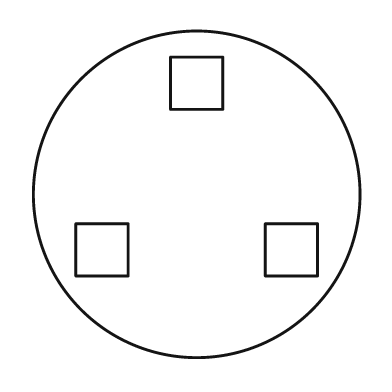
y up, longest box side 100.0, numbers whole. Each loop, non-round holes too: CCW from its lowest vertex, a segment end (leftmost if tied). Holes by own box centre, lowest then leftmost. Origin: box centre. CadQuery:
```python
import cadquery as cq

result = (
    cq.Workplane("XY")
    .moveTo(0.0, 0.0)
    .circle(50.0)
    .moveTo(-37.0, -25.0)
    .lineTo(-21.0, -25.0)
    .lineTo(-21.0, -9.0)
    .lineTo(-37.0, -9.0)
    .close()
    .moveTo(21.0, -25.0)
    .lineTo(37.0, -25.0)
    .lineTo(37.0, -9.0)
    .lineTo(21.0, -9.0)
    .close()
    .moveTo(-8.0, 26.0)
    .lineTo(8.0, 26.0)
    .lineTo(8.0, 42.0)
    .lineTo(-8.0, 42.0)
    .close()
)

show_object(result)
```